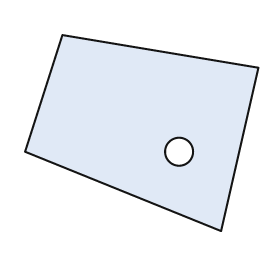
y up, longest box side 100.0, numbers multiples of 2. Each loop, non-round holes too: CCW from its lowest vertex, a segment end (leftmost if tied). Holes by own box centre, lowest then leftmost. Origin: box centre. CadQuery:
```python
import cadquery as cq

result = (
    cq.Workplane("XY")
    .moveTo(34.0, -42.0)
    .lineTo(50.0, 28.0)
    .lineTo(-34.0, 42.0)
    .lineTo(-50.0, -8.0)
    .close()
    .moveTo(16.0, -8.0)
    .circle(6.0)
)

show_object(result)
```